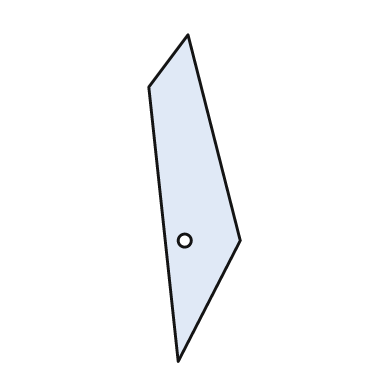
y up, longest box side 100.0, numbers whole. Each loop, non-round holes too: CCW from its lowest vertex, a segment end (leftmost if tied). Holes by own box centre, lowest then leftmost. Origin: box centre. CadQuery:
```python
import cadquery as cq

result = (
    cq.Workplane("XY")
    .moveTo(-5.0, -50.0)
    .lineTo(14.0, -13.0)
    .lineTo(-2.0, 50.0)
    .lineTo(-14.0, 34.0)
    .close()
    .moveTo(-3.0, -13.0)
    .circle(2.0)
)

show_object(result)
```